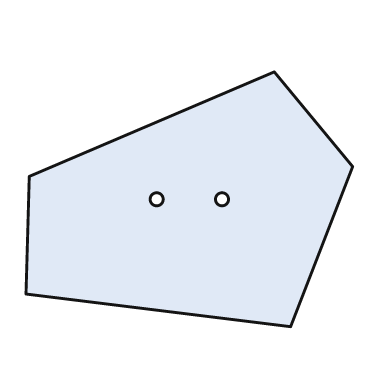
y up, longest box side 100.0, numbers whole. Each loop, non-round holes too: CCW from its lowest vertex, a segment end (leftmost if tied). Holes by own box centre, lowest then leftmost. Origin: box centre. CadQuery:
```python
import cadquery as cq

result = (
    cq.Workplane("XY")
    .moveTo(31.0, -39.0)
    .lineTo(50.0, 10.0)
    .lineTo(26.0, 39.0)
    .lineTo(-49.0, 7.0)
    .lineTo(-50.0, -29.0)
    .close()
    .moveTo(-10.0, 0.0)
    .circle(2.0)
    .moveTo(10.0, 0.0)
    .circle(2.0)
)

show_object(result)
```